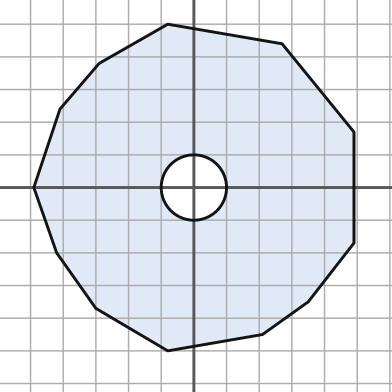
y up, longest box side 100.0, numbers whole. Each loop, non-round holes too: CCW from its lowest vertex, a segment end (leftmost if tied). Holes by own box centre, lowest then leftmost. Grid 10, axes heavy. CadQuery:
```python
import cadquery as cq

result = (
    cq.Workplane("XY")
    .moveTo(-8.0, -50.0)
    .lineTo(21.0, -45.0)
    .lineTo(35.0, -35.0)
    .lineTo(49.0, -17.0)
    .lineTo(49.0, 17.0)
    .lineTo(27.0, 44.0)
    .lineTo(-8.0, 50.0)
    .lineTo(-29.0, 38.0)
    .lineTo(-41.0, 24.0)
    .lineTo(-49.0, 0.0)
    .lineTo(-42.0, -20.0)
    .lineTo(-30.0, -37.0)
    .close()
    .moveTo(0.0, 0.0)
    .circle(10.0)
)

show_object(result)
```